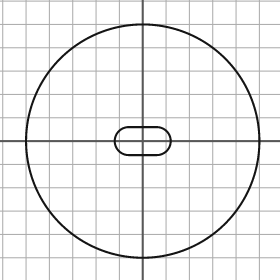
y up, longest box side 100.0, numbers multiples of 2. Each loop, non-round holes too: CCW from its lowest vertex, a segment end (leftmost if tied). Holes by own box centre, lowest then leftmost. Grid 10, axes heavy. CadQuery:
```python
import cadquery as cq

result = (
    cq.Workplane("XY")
    .moveTo(0.0, 0.0)
    .circle(50.0)
    .moveTo(-6.0, -6.0)
    .lineTo(6.0, -6.0)
    .threePointArc((12.0, 0.0), (6.0, 6.0))
    .lineTo(-6.0, 6.0)
    .threePointArc((-12.0, 0.0), (-6.0, -6.0))
    .close()
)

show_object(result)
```